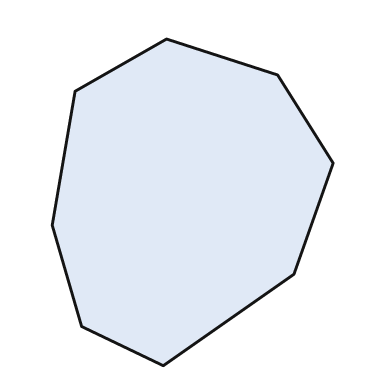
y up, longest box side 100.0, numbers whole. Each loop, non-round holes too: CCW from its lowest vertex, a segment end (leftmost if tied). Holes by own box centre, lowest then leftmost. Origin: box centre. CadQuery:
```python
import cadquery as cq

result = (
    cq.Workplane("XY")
    .moveTo(-9.0, -50.0)
    .lineTo(31.0, -22.0)
    .lineTo(43.0, 12.0)
    .lineTo(26.0, 39.0)
    .lineTo(-8.0, 50.0)
    .lineTo(-36.0, 34.0)
    .lineTo(-43.0, -7.0)
    .lineTo(-34.0, -38.0)
    .close()
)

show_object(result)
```